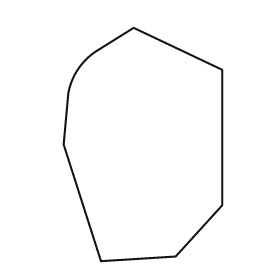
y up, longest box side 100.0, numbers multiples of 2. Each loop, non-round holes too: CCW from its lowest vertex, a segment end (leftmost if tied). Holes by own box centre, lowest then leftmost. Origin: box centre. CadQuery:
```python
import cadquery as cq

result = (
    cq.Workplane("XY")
    .moveTo(-18.0, -50.0)
    .lineTo(14.0, -48.0)
    .lineTo(34.0, -26.0)
    .lineTo(34.0, 32.0)
    .lineTo(-4.0, 50.0)
    .lineTo(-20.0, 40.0)
    .threePointArc((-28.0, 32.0), (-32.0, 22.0))
    .lineTo(-34.0, 0.0)
    .close()
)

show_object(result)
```